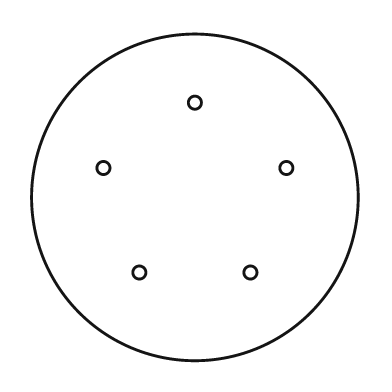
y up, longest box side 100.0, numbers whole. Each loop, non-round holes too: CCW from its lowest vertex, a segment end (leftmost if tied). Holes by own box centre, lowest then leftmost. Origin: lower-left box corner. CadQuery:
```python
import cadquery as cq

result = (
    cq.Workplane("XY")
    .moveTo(50.0, 50.0)
    .circle(50.0)
    .moveTo(33.0, 27.0)
    .circle(2.0)
    .moveTo(67.0, 27.0)
    .circle(2.0)
    .moveTo(22.0, 59.0)
    .circle(2.0)
    .moveTo(78.0, 59.0)
    .circle(2.0)
    .moveTo(50.0, 79.0)
    .circle(2.0)
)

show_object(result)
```